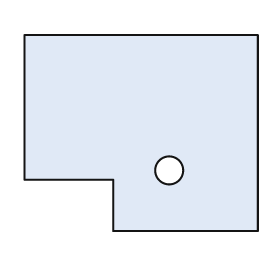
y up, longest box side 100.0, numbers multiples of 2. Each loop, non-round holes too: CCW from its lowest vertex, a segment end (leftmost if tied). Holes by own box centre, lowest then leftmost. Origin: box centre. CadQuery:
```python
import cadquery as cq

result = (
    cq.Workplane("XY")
    .moveTo(-12.0, -42.0)
    .lineTo(50.0, -42.0)
    .lineTo(50.0, 42.0)
    .lineTo(-50.0, 42.0)
    .lineTo(-50.0, -20.0)
    .lineTo(-12.0, -20.0)
    .close()
    .moveTo(12.0, -16.0)
    .circle(6.0)
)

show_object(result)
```